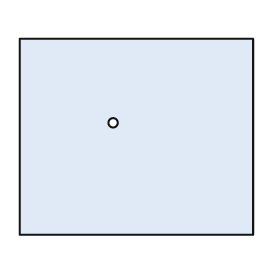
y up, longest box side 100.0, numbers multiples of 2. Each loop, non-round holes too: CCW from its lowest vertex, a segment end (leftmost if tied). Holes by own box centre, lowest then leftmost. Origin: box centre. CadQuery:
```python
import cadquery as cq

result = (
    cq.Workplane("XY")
    .moveTo(-50.0, -42.0)
    .lineTo(50.0, -42.0)
    .lineTo(50.0, 42.0)
    .lineTo(-50.0, 42.0)
    .close()
    .moveTo(-10.0, 6.0)
    .circle(2.0)
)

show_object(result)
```